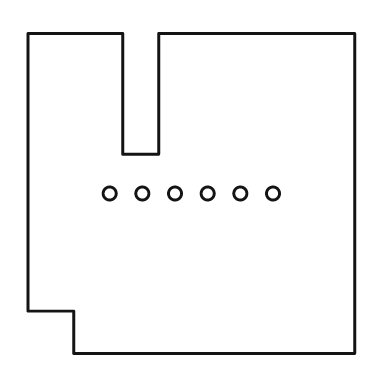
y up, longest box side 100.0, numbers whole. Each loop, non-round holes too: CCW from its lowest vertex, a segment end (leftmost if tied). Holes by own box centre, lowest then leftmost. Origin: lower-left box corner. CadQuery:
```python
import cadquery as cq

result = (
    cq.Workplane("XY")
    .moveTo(14.0, 0.0)
    .lineTo(100.0, 0.0)
    .lineTo(100.0, 98.0)
    .lineTo(40.0, 98.0)
    .lineTo(40.0, 61.0)
    .lineTo(29.0, 61.0)
    .lineTo(29.0, 98.0)
    .lineTo(0.0, 98.0)
    .lineTo(0.0, 13.0)
    .lineTo(14.0, 13.0)
    .close()
    .moveTo(25.0, 49.0)
    .circle(2.0)
    .moveTo(35.0, 49.0)
    .circle(2.0)
    .moveTo(45.0, 49.0)
    .circle(2.0)
    .moveTo(55.0, 49.0)
    .circle(2.0)
    .moveTo(65.0, 49.0)
    .circle(2.0)
    .moveTo(75.0, 49.0)
    .circle(2.0)
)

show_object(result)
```